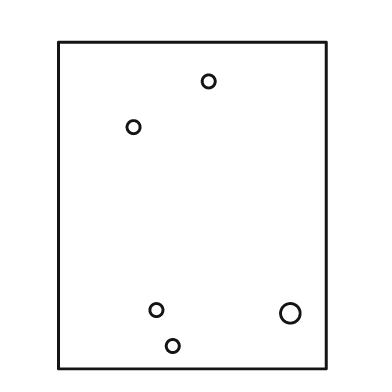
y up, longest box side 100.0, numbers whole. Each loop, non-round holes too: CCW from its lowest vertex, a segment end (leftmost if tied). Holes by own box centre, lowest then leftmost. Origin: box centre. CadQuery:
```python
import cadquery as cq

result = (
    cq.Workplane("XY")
    .moveTo(-41.0, -50.0)
    .lineTo(41.0, -50.0)
    .lineTo(41.0, 50.0)
    .lineTo(-41.0, 50.0)
    .close()
    .moveTo(-6.0, -43.0)
    .circle(2.0)
    .moveTo(30.0, -33.0)
    .circle(3.0)
    .moveTo(-11.0, -32.0)
    .circle(2.0)
    .moveTo(-18.0, 24.0)
    .circle(2.0)
    .moveTo(5.0, 38.0)
    .circle(2.0)
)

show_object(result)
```